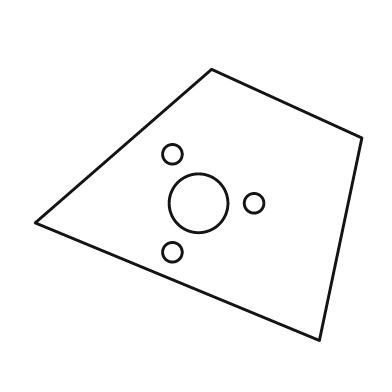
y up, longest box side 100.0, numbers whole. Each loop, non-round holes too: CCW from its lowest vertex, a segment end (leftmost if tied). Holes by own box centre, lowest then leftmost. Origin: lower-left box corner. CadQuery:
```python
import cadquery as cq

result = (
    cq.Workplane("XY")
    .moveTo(87.0, 0.0)
    .lineTo(100.0, 62.0)
    .lineTo(54.0, 83.0)
    .lineTo(0.0, 36.0)
    .close()
    .moveTo(42.0, 27.0)
    .circle(3.0)
    .moveTo(50.0, 42.0)
    .circle(9.0)
    .moveTo(67.0, 42.0)
    .circle(3.0)
    .moveTo(42.0, 57.0)
    .circle(3.0)
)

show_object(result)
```